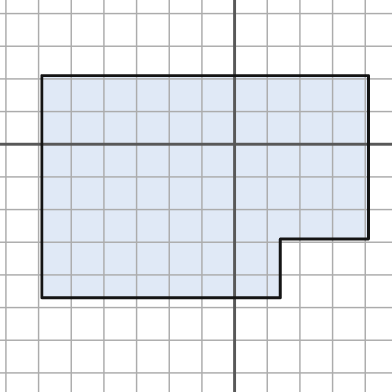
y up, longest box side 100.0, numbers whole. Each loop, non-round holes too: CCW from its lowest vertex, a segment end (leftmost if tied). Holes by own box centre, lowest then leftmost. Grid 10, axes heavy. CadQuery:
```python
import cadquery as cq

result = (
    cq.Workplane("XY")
    .moveTo(-59.0, -47.0)
    .lineTo(14.0, -47.0)
    .lineTo(14.0, -29.0)
    .lineTo(41.0, -29.0)
    .lineTo(41.0, 21.0)
    .lineTo(-59.0, 21.0)
    .close()
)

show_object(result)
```